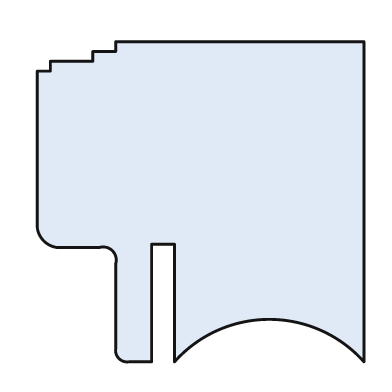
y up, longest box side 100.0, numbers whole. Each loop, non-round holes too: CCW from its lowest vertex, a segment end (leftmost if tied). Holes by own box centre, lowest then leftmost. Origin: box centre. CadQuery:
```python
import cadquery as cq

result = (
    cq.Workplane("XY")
    .moveTo(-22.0, -49.0)
    .lineTo(-15.0, -49.0)
    .lineTo(-15.0, -13.0)
    .lineTo(-8.0, -13.0)
    .lineTo(-8.0, -49.0)
    .threePointArc((21.0, -36.0), (50.0, -49.0))
    .lineTo(50.0, 49.0)
    .lineTo(-26.0, 49.0)
    .lineTo(-26.0, 46.0)
    .lineTo(-33.0, 46.0)
    .lineTo(-33.0, 43.0)
    .lineTo(-46.0, 43.0)
    .lineTo(-46.0, 40.0)
    .lineTo(-50.0, 40.0)
    .lineTo(-50.0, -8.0)
    .threePointArc((-48.0, -12.0), (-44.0, -14.0))
    .lineTo(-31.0, -14.0)
    .threePointArc((-27.0, -15.0), (-26.0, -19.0))
    .lineTo(-26.0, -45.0)
    .threePointArc((-25.0, -48.0), (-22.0, -49.0))
    .close()
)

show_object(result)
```